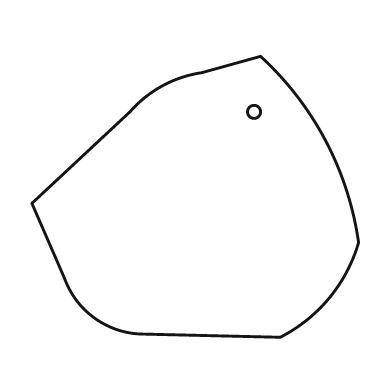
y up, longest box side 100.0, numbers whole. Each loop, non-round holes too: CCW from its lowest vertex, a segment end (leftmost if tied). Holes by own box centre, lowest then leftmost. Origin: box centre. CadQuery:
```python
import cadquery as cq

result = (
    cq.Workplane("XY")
    .moveTo(26.0, -43.0)
    .threePointArc((41.0, -31.0), (50.0, -14.0))
    .threePointArc((40.0, 17.0), (20.0, 43.0))
    .lineTo(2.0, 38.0)
    .threePointArc((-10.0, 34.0), (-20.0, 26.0))
    .lineTo(-50.0, -2.0)
    .lineTo(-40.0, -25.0)
    .threePointArc((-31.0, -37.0), (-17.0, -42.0))
    .close()
    .moveTo(18.0, 26.0)
    .circle(2.0)
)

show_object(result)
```